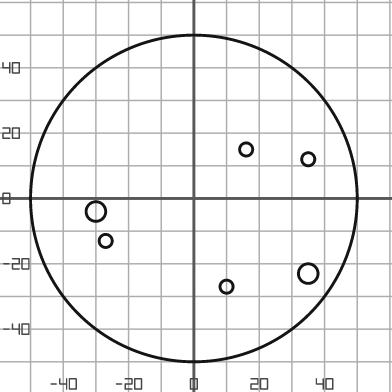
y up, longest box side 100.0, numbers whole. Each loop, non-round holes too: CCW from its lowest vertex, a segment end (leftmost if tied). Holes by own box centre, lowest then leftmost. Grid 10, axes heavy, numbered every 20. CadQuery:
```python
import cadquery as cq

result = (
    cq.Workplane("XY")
    .moveTo(0.0, 0.0)
    .circle(50.0)
    .moveTo(10.0, -27.0)
    .circle(2.0)
    .moveTo(35.0, -23.0)
    .circle(3.0)
    .moveTo(-27.0, -13.0)
    .circle(2.0)
    .moveTo(-30.0, -4.0)
    .circle(3.0)
    .moveTo(35.0, 12.0)
    .circle(2.0)
    .moveTo(16.0, 15.0)
    .circle(2.0)
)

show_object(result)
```